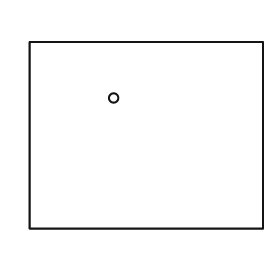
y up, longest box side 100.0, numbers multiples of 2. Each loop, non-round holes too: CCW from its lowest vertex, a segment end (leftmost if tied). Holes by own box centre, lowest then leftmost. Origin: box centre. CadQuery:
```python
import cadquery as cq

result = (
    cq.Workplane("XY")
    .moveTo(-50.0, -40.0)
    .lineTo(50.0, -40.0)
    .lineTo(50.0, 40.0)
    .lineTo(-50.0, 40.0)
    .close()
    .moveTo(-14.0, 16.0)
    .circle(2.0)
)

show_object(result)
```